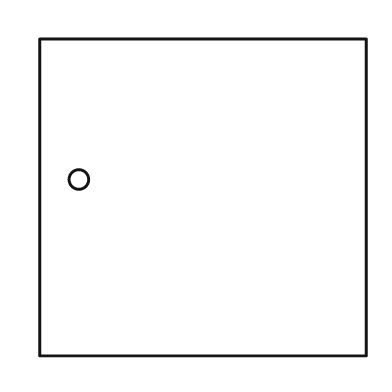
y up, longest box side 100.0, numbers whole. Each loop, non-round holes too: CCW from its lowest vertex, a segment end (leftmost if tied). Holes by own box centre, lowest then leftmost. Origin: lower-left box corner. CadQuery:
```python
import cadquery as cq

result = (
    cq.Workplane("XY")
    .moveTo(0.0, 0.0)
    .lineTo(100.0, 0.0)
    .lineTo(100.0, 97.0)
    .lineTo(0.0, 97.0)
    .close()
    .moveTo(12.0, 54.0)
    .circle(3.0)
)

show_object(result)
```